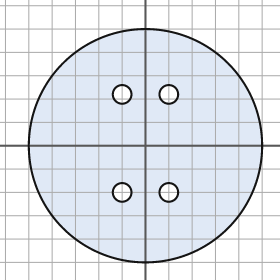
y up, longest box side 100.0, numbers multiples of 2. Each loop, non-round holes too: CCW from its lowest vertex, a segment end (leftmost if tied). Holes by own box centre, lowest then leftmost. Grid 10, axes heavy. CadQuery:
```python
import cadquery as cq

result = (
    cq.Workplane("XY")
    .moveTo(0.0, 0.0)
    .circle(50.0)
    .moveTo(-10.0, -20.0)
    .circle(4.0)
    .moveTo(10.0, -20.0)
    .circle(4.0)
    .moveTo(-10.0, 22.0)
    .circle(4.0)
    .moveTo(10.0, 22.0)
    .circle(4.0)
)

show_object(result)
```